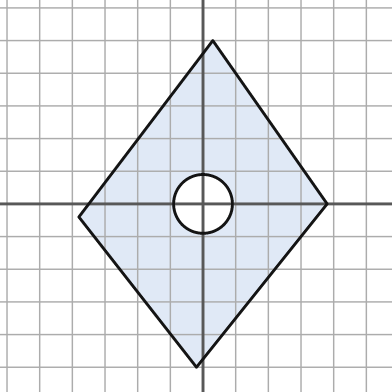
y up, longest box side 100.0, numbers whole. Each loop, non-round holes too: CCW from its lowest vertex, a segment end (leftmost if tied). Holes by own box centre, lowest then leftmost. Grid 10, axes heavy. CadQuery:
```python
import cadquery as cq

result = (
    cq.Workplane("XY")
    .moveTo(-2.0, -50.0)
    .lineTo(38.0, 0.0)
    .lineTo(3.0, 50.0)
    .lineTo(-38.0, -4.0)
    .close()
    .moveTo(0.0, 0.0)
    .circle(9.0)
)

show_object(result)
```